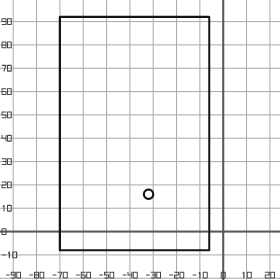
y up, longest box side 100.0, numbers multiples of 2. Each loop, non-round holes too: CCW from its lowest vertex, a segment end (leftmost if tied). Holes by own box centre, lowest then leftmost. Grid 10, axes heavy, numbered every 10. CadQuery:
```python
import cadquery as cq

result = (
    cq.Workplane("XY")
    .moveTo(-70.0, -8.0)
    .lineTo(-6.0, -8.0)
    .lineTo(-6.0, 92.0)
    .lineTo(-70.0, 92.0)
    .close()
    .moveTo(-32.0, 16.0)
    .circle(2.0)
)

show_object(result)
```